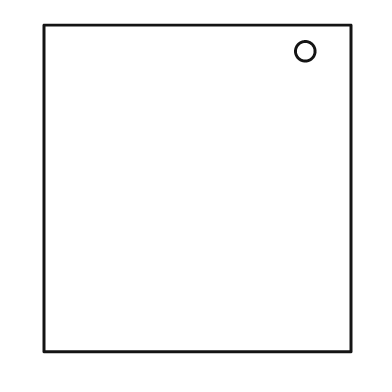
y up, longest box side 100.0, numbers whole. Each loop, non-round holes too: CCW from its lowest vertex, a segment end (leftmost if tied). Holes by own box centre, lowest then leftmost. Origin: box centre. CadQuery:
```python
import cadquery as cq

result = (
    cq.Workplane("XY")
    .moveTo(-47.0, -50.0)
    .lineTo(47.0, -50.0)
    .lineTo(47.0, 50.0)
    .lineTo(-47.0, 50.0)
    .close()
    .moveTo(33.0, 42.0)
    .circle(3.0)
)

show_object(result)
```